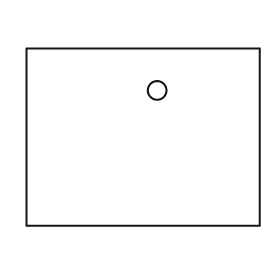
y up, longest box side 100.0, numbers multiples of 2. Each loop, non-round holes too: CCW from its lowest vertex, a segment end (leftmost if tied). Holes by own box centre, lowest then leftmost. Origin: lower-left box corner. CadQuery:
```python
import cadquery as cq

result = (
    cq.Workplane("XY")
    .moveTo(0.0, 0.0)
    .lineTo(100.0, 0.0)
    .lineTo(100.0, 76.0)
    .lineTo(0.0, 76.0)
    .close()
    .moveTo(56.0, 58.0)
    .circle(4.0)
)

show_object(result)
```